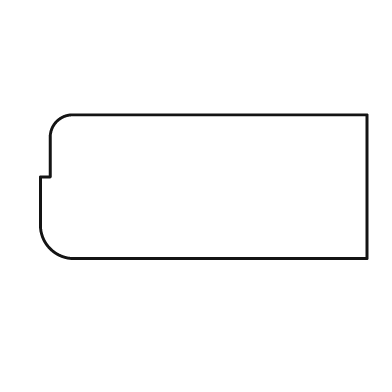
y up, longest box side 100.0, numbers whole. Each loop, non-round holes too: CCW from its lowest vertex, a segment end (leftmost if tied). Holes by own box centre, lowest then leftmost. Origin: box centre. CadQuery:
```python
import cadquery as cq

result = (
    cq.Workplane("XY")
    .moveTo(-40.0, -22.0)
    .lineTo(50.0, -22.0)
    .lineTo(50.0, 22.0)
    .lineTo(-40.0, 22.0)
    .threePointArc((-45.0, 20.0), (-47.0, 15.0))
    .lineTo(-47.0, 3.0)
    .lineTo(-50.0, 3.0)
    .lineTo(-50.0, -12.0)
    .threePointArc((-47.0, -19.0), (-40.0, -22.0))
    .close()
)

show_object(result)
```